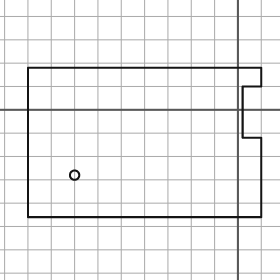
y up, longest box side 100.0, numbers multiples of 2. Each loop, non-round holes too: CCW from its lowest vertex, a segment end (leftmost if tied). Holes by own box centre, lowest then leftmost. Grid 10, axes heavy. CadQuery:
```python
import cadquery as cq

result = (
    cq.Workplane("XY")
    .moveTo(-90.0, -46.0)
    .lineTo(10.0, -46.0)
    .lineTo(10.0, -12.0)
    .lineTo(2.0, -12.0)
    .lineTo(2.0, 10.0)
    .lineTo(10.0, 10.0)
    .lineTo(10.0, 18.0)
    .lineTo(-90.0, 18.0)
    .close()
    .moveTo(-70.0, -28.0)
    .circle(2.0)
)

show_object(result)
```